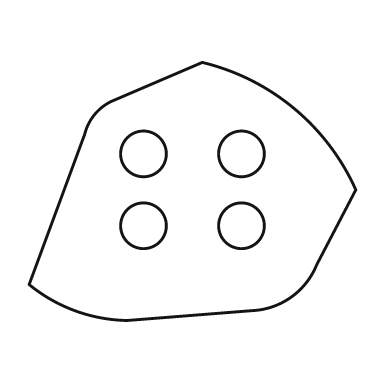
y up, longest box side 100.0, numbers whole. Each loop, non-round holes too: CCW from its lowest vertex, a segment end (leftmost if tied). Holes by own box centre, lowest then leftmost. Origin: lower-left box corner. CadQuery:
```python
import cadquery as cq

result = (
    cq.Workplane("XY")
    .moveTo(30.0, 0.0)
    .lineTo(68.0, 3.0)
    .threePointArc((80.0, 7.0), (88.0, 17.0))
    .lineTo(100.0, 40.0)
    .threePointArc((81.0, 65.0), (53.0, 79.0))
    .lineTo(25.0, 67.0)
    .threePointArc((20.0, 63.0), (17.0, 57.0))
    .lineTo(0.0, 11.0)
    .threePointArc((14.0, 3.0), (30.0, 0.0))
    .close()
    .moveTo(35.0, 29.0)
    .circle(7.0)
    .moveTo(65.0, 29.0)
    .circle(7.0)
    .moveTo(35.0, 51.0)
    .circle(7.0)
    .moveTo(65.0, 51.0)
    .circle(7.0)
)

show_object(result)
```